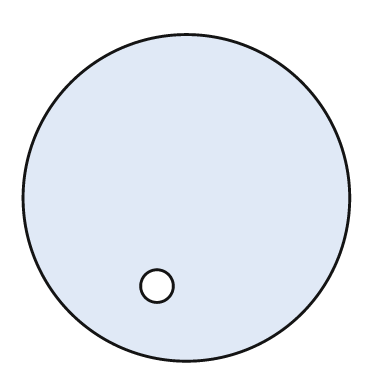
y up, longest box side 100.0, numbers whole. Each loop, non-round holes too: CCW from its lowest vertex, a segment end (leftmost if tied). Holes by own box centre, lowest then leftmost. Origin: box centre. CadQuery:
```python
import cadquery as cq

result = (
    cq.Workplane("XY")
    .moveTo(0.0, 0.0)
    .circle(50.0)
    .moveTo(-9.0, -27.0)
    .circle(5.0)
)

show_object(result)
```